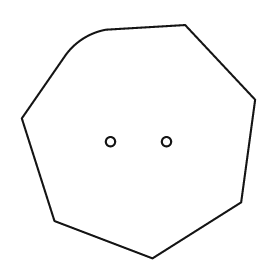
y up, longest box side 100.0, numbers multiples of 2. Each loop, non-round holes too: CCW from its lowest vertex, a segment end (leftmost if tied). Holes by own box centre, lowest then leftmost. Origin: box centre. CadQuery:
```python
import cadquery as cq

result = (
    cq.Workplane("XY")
    .moveTo(6.0, -50.0)
    .lineTo(44.0, -26.0)
    .lineTo(50.0, 18.0)
    .lineTo(20.0, 50.0)
    .lineTo(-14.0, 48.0)
    .threePointArc((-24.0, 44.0), (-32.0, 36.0))
    .lineTo(-50.0, 10.0)
    .lineTo(-36.0, -34.0)
    .close()
    .moveTo(-12.0, 0.0)
    .circle(2.0)
    .moveTo(12.0, 0.0)
    .circle(2.0)
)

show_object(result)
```